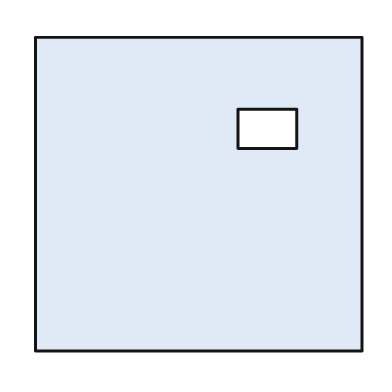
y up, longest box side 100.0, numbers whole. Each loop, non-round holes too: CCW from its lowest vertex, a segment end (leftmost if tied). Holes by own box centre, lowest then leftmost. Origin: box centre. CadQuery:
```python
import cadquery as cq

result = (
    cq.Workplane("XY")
    .moveTo(-50.0, -48.0)
    .lineTo(50.0, -48.0)
    .lineTo(50.0, 48.0)
    .lineTo(-50.0, 48.0)
    .close()
    .moveTo(12.0, 14.0)
    .lineTo(30.0, 14.0)
    .lineTo(30.0, 26.0)
    .lineTo(12.0, 26.0)
    .close()
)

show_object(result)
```